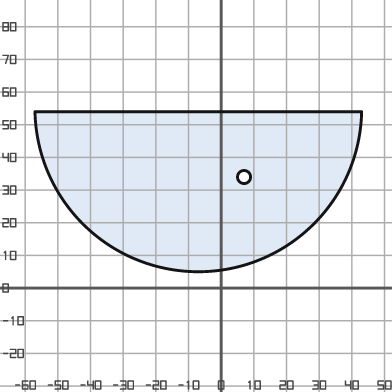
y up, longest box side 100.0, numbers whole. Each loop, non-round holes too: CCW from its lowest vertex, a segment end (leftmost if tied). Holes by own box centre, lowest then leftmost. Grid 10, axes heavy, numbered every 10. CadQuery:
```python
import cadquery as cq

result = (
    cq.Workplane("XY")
    .moveTo(-57.0, 54.0)
    .threePointArc((-7.0, 5.0), (43.0, 54.0))
    .close()
    .moveTo(7.0, 34.0)
    .circle(2.0)
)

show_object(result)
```